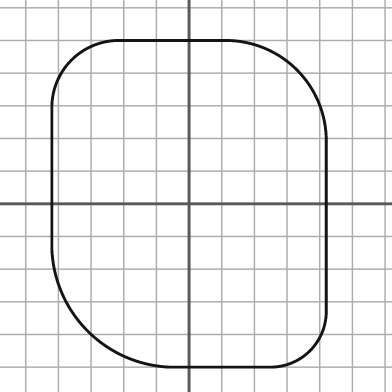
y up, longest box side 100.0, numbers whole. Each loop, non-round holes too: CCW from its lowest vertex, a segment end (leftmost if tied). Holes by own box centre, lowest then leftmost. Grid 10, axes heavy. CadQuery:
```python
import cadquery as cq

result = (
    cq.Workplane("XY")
    .moveTo(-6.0, -50.0)
    .lineTo(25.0, -50.0)
    .threePointArc((37.0, -45.0), (42.0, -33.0))
    .lineTo(42.0, 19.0)
    .threePointArc((33.0, 41.0), (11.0, 50.0))
    .lineTo(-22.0, 50.0)
    .threePointArc((-36.0, 44.0), (-42.0, 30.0))
    .lineTo(-42.0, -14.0)
    .threePointArc((-31.0, -39.0), (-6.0, -50.0))
    .close()
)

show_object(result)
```